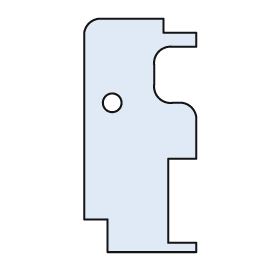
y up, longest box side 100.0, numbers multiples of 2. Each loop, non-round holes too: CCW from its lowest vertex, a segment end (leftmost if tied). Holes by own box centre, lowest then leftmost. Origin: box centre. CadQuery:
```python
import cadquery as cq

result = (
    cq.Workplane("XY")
    .moveTo(-14.0, -50.0)
    .lineTo(24.0, -50.0)
    .lineTo(24.0, -46.0)
    .lineTo(12.0, -46.0)
    .lineTo(12.0, -10.0)
    .lineTo(24.0, -10.0)
    .lineTo(24.0, 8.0)
    .threePointArc((22.0, 12.0), (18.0, 14.0))
    .lineTo(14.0, 14.0)
    .threePointArc((8.0, 16.0), (6.0, 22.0))
    .lineTo(6.0, 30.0)
    .threePointArc((8.0, 36.0), (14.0, 38.0))
    .lineTo(24.0, 38.0)
    .lineTo(24.0, 44.0)
    .lineTo(10.0, 44.0)
    .lineTo(10.0, 50.0)
    .lineTo(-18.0, 50.0)
    .threePointArc((-22.0, 48.0), (-24.0, 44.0))
    .lineTo(-24.0, -36.0)
    .lineTo(-14.0, -36.0)
    .close()
    .moveTo(-12.0, 14.0)
    .circle(4.0)
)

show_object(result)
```